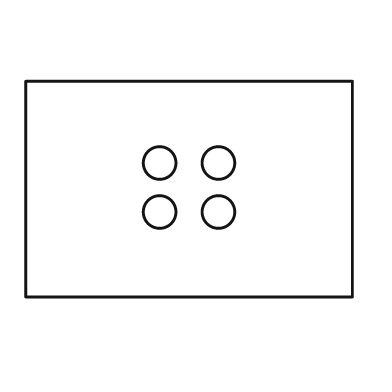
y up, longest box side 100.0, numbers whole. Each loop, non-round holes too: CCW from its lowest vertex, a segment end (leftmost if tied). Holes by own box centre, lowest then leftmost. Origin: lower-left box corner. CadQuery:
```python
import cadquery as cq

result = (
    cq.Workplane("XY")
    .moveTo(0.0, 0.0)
    .lineTo(100.0, 0.0)
    .lineTo(100.0, 66.0)
    .lineTo(0.0, 66.0)
    .close()
    .moveTo(41.0, 26.0)
    .circle(5.0)
    .moveTo(59.0, 26.0)
    .circle(5.0)
    .moveTo(41.0, 41.0)
    .circle(5.0)
    .moveTo(59.0, 41.0)
    .circle(5.0)
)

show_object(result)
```